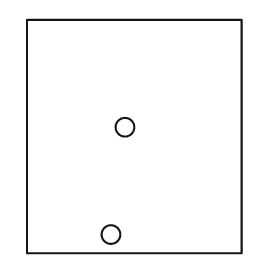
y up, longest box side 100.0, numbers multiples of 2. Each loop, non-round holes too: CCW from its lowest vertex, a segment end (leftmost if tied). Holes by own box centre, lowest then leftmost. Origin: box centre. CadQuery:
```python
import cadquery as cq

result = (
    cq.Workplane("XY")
    .moveTo(-46.0, -50.0)
    .lineTo(46.0, -50.0)
    .lineTo(46.0, 50.0)
    .lineTo(-46.0, 50.0)
    .close()
    .moveTo(-10.0, -42.0)
    .circle(4.0)
    .moveTo(-4.0, 4.0)
    .circle(4.0)
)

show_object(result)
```